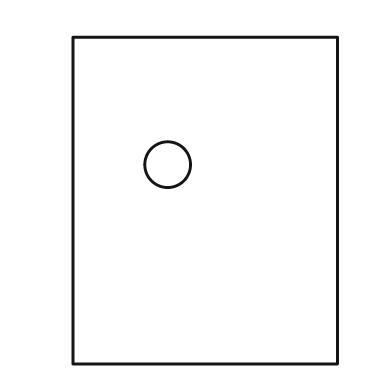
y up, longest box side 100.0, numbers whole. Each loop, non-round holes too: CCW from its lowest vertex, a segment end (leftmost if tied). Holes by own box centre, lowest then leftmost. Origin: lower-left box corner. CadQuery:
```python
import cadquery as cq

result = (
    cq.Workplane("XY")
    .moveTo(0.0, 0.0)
    .lineTo(81.0, 0.0)
    .lineTo(81.0, 100.0)
    .lineTo(0.0, 100.0)
    .close()
    .moveTo(29.0, 61.0)
    .circle(7.0)
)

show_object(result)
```